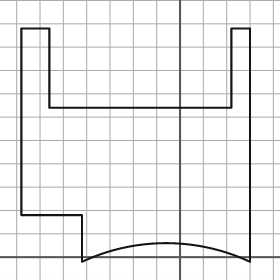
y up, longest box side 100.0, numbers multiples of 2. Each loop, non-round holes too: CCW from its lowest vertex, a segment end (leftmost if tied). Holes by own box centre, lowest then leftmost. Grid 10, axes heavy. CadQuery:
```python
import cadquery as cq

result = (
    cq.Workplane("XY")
    .moveTo(-42.0, -2.0)
    .threePointArc((-6.0, 6.0), (30.0, -2.0))
    .lineTo(30.0, 98.0)
    .lineTo(22.0, 98.0)
    .lineTo(22.0, 64.0)
    .lineTo(-56.0, 64.0)
    .lineTo(-56.0, 98.0)
    .lineTo(-68.0, 98.0)
    .lineTo(-68.0, 18.0)
    .lineTo(-42.0, 18.0)
    .close()
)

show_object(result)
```